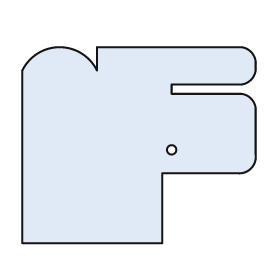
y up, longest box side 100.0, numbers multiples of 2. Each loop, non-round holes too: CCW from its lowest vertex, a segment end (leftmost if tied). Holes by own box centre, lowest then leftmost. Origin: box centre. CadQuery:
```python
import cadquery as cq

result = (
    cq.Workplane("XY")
    .moveTo(-50.0, -42.0)
    .lineTo(10.0, -42.0)
    .lineTo(10.0, -12.0)
    .lineTo(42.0, -12.0)
    .threePointArc((48.0, -10.0), (50.0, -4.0))
    .lineTo(50.0, 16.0)
    .threePointArc((48.0, 20.0), (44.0, 22.0))
    .lineTo(14.0, 22.0)
    .lineTo(14.0, 26.0)
    .lineTo(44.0, 26.0)
    .threePointArc((48.0, 28.0), (50.0, 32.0))
    .lineTo(50.0, 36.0)
    .threePointArc((48.0, 40.0), (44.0, 42.0))
    .lineTo(-18.0, 42.0)
    .lineTo(-18.0, 32.0)
    .threePointArc((-34.0, 42.0), (-50.0, 32.0))
    .close()
    .moveTo(14.0, -2.0)
    .circle(2.0)
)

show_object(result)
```